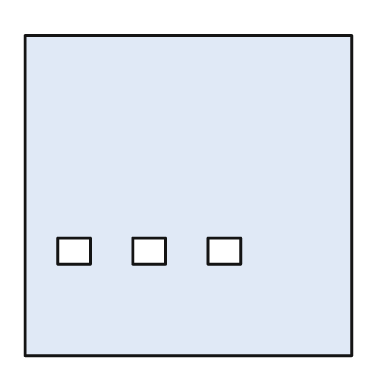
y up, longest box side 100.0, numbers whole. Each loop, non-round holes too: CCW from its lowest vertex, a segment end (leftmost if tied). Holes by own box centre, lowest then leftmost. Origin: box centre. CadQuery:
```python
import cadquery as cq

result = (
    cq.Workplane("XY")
    .moveTo(-50.0, -49.0)
    .lineTo(50.0, -49.0)
    .lineTo(50.0, 49.0)
    .lineTo(-50.0, 49.0)
    .close()
    .moveTo(-40.0, -21.0)
    .lineTo(-30.0, -21.0)
    .lineTo(-30.0, -13.0)
    .lineTo(-40.0, -13.0)
    .close()
    .moveTo(-17.0, -21.0)
    .lineTo(-7.0, -21.0)
    .lineTo(-7.0, -13.0)
    .lineTo(-17.0, -13.0)
    .close()
    .moveTo(6.0, -21.0)
    .lineTo(16.0, -21.0)
    .lineTo(16.0, -13.0)
    .lineTo(6.0, -13.0)
    .close()
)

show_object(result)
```